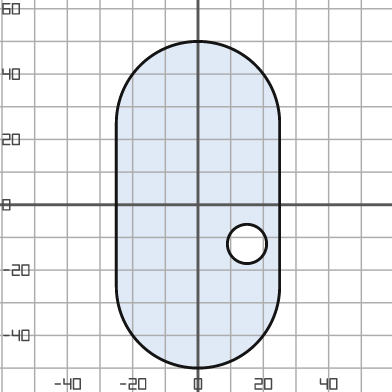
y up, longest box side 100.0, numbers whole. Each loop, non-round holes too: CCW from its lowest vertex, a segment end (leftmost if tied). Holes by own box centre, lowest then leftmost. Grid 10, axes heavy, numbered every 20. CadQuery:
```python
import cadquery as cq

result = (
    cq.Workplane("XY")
    .moveTo(-25.0, -25.0)
    .threePointArc((0.0, -50.0), (25.0, -25.0))
    .lineTo(25.0, 25.0)
    .threePointArc((0.0, 50.0), (-25.0, 25.0))
    .close()
    .moveTo(15.0, -12.0)
    .circle(6.0)
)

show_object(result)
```